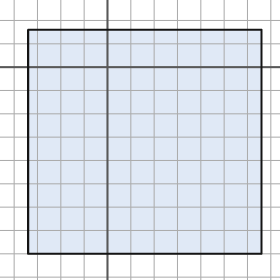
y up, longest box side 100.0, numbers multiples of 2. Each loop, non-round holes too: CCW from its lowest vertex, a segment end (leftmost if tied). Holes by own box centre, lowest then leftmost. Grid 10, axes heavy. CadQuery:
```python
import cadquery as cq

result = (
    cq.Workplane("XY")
    .moveTo(-34.0, -80.0)
    .lineTo(66.0, -80.0)
    .lineTo(66.0, 16.0)
    .lineTo(-34.0, 16.0)
    .close()
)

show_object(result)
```